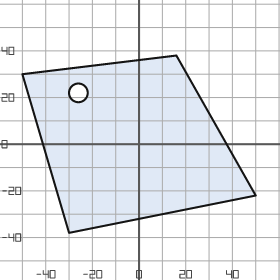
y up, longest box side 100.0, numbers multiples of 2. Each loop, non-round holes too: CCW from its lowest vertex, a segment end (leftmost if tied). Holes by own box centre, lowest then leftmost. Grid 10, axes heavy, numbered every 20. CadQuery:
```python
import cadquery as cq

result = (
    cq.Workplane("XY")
    .moveTo(-30.0, -38.0)
    .lineTo(50.0, -22.0)
    .lineTo(16.0, 38.0)
    .lineTo(-50.0, 30.0)
    .close()
    .moveTo(-26.0, 22.0)
    .circle(4.0)
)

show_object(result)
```